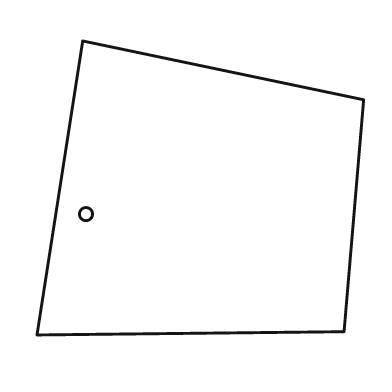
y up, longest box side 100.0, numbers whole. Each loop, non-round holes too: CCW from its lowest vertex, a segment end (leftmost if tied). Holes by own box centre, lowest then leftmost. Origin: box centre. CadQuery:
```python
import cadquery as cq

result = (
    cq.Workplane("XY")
    .moveTo(-50.0, -45.0)
    .lineTo(44.0, -44.0)
    .lineTo(50.0, 27.0)
    .lineTo(-36.0, 45.0)
    .close()
    .moveTo(-35.0, -8.0)
    .circle(2.0)
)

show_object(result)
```